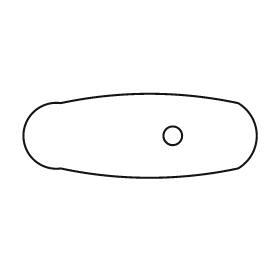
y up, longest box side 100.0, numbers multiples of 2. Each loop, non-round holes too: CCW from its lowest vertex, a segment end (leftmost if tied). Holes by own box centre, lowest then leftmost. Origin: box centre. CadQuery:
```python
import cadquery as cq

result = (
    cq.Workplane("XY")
    .moveTo(-34.0, -14.0)
    .threePointArc((4.0, -18.0), (42.0, -14.0))
    .threePointArc((50.0, 0.0), (42.0, 14.0))
    .threePointArc((4.0, 18.0), (-34.0, 14.0))
    .threePointArc((-50.0, 0.0), (-34.0, -14.0))
    .close()
    .moveTo(14.0, 0.0)
    .circle(4.0)
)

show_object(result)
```